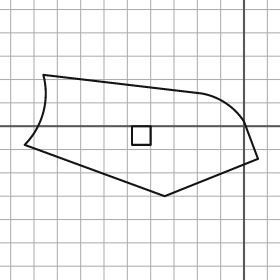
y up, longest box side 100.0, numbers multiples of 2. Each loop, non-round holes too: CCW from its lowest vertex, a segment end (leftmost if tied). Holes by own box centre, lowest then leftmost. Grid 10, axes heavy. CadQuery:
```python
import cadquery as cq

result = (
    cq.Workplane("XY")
    .moveTo(-34.0, -30.0)
    .lineTo(6.0, -14.0)
    .lineTo(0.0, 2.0)
    .threePointArc((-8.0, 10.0), (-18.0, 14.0))
    .lineTo(-86.0, 22.0)
    .threePointArc((-86.0, 6.0), (-94.0, -8.0))
    .close()
    .moveTo(-48.0, -8.0)
    .lineTo(-40.0, -8.0)
    .lineTo(-40.0, 0.0)
    .lineTo(-48.0, 0.0)
    .close()
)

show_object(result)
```